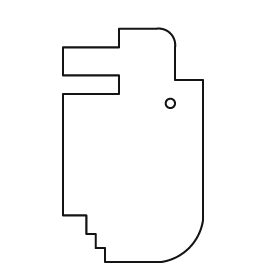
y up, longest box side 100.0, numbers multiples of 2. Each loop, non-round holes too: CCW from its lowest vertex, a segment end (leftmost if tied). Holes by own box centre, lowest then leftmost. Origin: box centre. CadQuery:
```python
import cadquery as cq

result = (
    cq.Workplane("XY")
    .moveTo(-12.0, -50.0)
    .lineTo(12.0, -50.0)
    .threePointArc((24.0, -44.0), (30.0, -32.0))
    .lineTo(30.0, 28.0)
    .lineTo(18.0, 28.0)
    .lineTo(18.0, 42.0)
    .threePointArc((16.0, 48.0), (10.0, 50.0))
    .lineTo(-6.0, 50.0)
    .lineTo(-6.0, 42.0)
    .lineTo(-30.0, 42.0)
    .lineTo(-30.0, 30.0)
    .lineTo(-6.0, 30.0)
    .lineTo(-6.0, 22.0)
    .lineTo(-30.0, 22.0)
    .lineTo(-30.0, -30.0)
    .lineTo(-20.0, -30.0)
    .lineTo(-20.0, -38.0)
    .lineTo(-16.0, -38.0)
    .lineTo(-16.0, -44.0)
    .lineTo(-12.0, -44.0)
    .close()
    .moveTo(16.0, 18.0)
    .circle(2.0)
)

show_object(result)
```